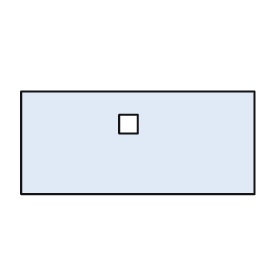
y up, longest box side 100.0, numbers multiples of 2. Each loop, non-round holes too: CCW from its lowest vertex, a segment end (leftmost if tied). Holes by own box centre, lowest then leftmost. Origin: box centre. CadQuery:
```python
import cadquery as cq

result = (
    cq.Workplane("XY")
    .moveTo(-50.0, -22.0)
    .lineTo(50.0, -22.0)
    .lineTo(50.0, 22.0)
    .lineTo(-50.0, 22.0)
    .close()
    .moveTo(-8.0, 4.0)
    .lineTo(0.0, 4.0)
    .lineTo(0.0, 12.0)
    .lineTo(-8.0, 12.0)
    .close()
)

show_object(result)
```